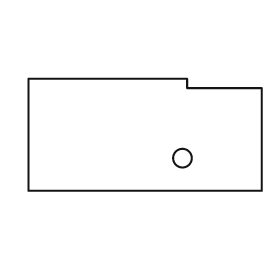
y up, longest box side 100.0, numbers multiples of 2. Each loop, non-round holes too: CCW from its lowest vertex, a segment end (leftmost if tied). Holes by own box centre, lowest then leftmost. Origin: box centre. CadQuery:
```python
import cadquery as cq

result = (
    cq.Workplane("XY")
    .moveTo(-50.0, -24.0)
    .lineTo(50.0, -24.0)
    .lineTo(50.0, 20.0)
    .lineTo(18.0, 20.0)
    .lineTo(18.0, 24.0)
    .lineTo(-50.0, 24.0)
    .close()
    .moveTo(16.0, -10.0)
    .circle(4.0)
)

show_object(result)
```